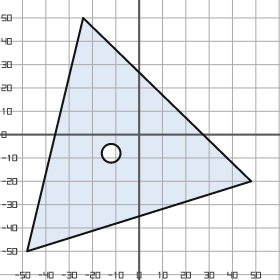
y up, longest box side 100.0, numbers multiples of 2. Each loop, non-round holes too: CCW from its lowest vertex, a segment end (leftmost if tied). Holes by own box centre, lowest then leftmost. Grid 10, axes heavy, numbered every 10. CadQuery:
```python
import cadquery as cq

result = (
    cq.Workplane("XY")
    .moveTo(-48.0, -50.0)
    .lineTo(48.0, -20.0)
    .lineTo(-24.0, 50.0)
    .close()
    .moveTo(-12.0, -8.0)
    .circle(4.0)
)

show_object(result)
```